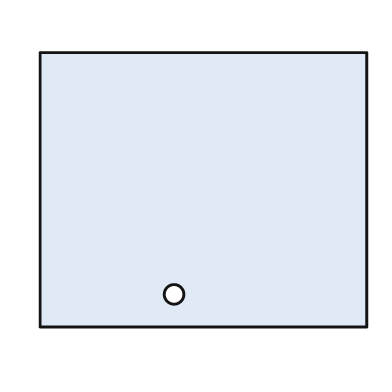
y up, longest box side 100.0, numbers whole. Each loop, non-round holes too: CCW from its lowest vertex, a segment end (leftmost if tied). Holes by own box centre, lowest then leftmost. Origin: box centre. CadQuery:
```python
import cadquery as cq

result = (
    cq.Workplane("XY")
    .moveTo(-50.0, -42.0)
    .lineTo(50.0, -42.0)
    .lineTo(50.0, 42.0)
    .lineTo(-50.0, 42.0)
    .close()
    .moveTo(-9.0, -32.0)
    .circle(3.0)
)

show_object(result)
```